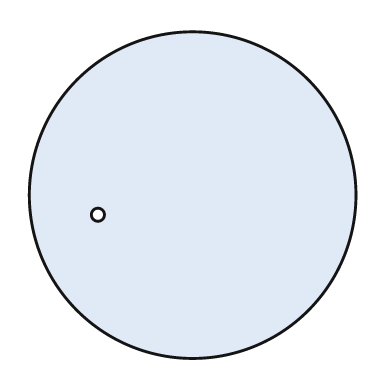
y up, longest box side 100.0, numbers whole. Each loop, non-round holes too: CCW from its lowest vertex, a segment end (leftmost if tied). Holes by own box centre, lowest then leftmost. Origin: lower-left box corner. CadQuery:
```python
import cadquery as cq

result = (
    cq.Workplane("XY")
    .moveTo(50.0, 50.0)
    .circle(50.0)
    .moveTo(21.0, 44.0)
    .circle(2.0)
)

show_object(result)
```